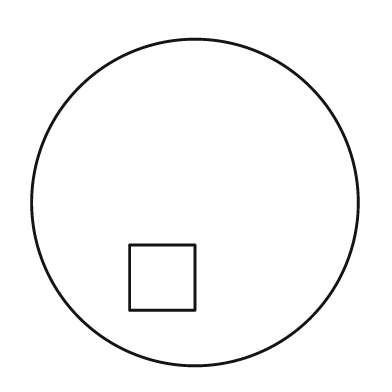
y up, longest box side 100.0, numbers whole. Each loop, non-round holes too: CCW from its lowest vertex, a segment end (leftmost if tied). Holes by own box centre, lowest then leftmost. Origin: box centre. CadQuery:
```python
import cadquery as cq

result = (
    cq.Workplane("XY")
    .moveTo(0.0, 0.0)
    .circle(50.0)
    .moveTo(-20.0, -33.0)
    .lineTo(0.0, -33.0)
    .lineTo(0.0, -13.0)
    .lineTo(-20.0, -13.0)
    .close()
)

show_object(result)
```